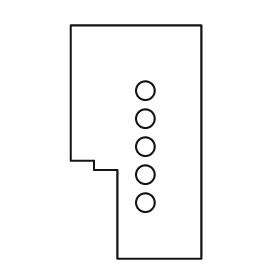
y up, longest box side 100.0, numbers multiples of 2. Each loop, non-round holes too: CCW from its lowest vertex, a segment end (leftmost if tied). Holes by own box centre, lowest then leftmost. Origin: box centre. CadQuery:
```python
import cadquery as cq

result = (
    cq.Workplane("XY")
    .moveTo(-8.0, -50.0)
    .lineTo(28.0, -50.0)
    .lineTo(28.0, 50.0)
    .lineTo(-28.0, 50.0)
    .lineTo(-28.0, -8.0)
    .lineTo(-18.0, -8.0)
    .lineTo(-18.0, -12.0)
    .lineTo(-8.0, -12.0)
    .close()
    .moveTo(4.0, -26.0)
    .circle(4.0)
    .moveTo(4.0, -14.0)
    .circle(4.0)
    .moveTo(4.0, -2.0)
    .circle(4.0)
    .moveTo(4.0, 10.0)
    .circle(4.0)
    .moveTo(4.0, 22.0)
    .circle(4.0)
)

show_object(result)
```